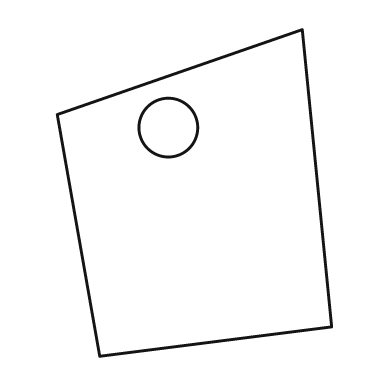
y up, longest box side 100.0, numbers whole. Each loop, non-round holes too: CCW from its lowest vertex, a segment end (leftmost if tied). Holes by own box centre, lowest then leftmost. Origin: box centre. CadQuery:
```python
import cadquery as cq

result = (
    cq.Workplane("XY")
    .moveTo(-29.0, -50.0)
    .lineTo(42.0, -41.0)
    .lineTo(33.0, 50.0)
    .lineTo(-42.0, 24.0)
    .close()
    .moveTo(-8.0, 20.0)
    .circle(9.0)
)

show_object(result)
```